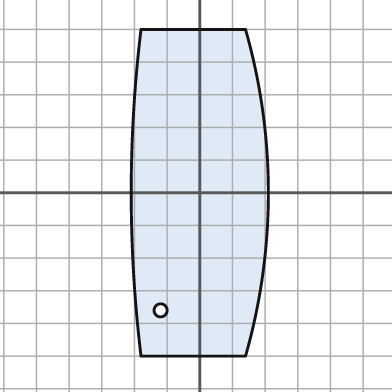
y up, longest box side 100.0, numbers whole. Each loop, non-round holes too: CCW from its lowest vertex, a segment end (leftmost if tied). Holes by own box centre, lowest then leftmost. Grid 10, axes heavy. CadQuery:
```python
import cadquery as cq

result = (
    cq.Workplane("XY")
    .moveTo(-18.0, -50.0)
    .lineTo(14.0, -50.0)
    .threePointArc((21.0, 0.0), (14.0, 50.0))
    .lineTo(-18.0, 50.0)
    .threePointArc((-21.0, 0.0), (-18.0, -50.0))
    .close()
    .moveTo(-12.0, -36.0)
    .circle(2.0)
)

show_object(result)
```